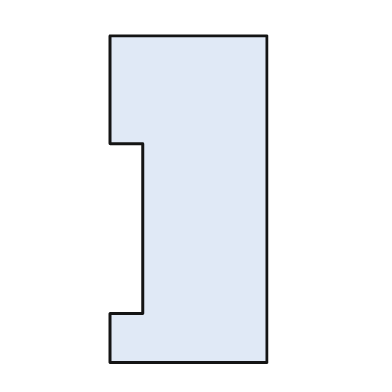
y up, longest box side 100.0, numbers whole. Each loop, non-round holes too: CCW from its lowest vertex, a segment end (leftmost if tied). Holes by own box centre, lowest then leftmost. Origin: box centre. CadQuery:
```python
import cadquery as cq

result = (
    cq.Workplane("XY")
    .moveTo(-24.0, -50.0)
    .lineTo(24.0, -50.0)
    .lineTo(24.0, 50.0)
    .lineTo(-24.0, 50.0)
    .lineTo(-24.0, 17.0)
    .lineTo(-14.0, 17.0)
    .lineTo(-14.0, -35.0)
    .lineTo(-24.0, -35.0)
    .close()
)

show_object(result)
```